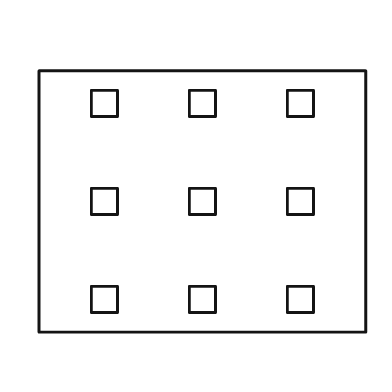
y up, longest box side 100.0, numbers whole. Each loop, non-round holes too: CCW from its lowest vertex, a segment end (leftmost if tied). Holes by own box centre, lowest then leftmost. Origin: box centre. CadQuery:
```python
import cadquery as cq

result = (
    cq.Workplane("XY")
    .moveTo(-50.0, -40.0)
    .lineTo(50.0, -40.0)
    .lineTo(50.0, 40.0)
    .lineTo(-50.0, 40.0)
    .close()
    .moveTo(-34.0, -34.0)
    .lineTo(-26.0, -34.0)
    .lineTo(-26.0, -26.0)
    .lineTo(-34.0, -26.0)
    .close()
    .moveTo(-4.0, -34.0)
    .lineTo(4.0, -34.0)
    .lineTo(4.0, -26.0)
    .lineTo(-4.0, -26.0)
    .close()
    .moveTo(26.0, -34.0)
    .lineTo(34.0, -34.0)
    .lineTo(34.0, -26.0)
    .lineTo(26.0, -26.0)
    .close()
    .moveTo(-34.0, -4.0)
    .lineTo(-26.0, -4.0)
    .lineTo(-26.0, 4.0)
    .lineTo(-34.0, 4.0)
    .close()
    .moveTo(-4.0, -4.0)
    .lineTo(4.0, -4.0)
    .lineTo(4.0, 4.0)
    .lineTo(-4.0, 4.0)
    .close()
    .moveTo(26.0, -4.0)
    .lineTo(34.0, -4.0)
    .lineTo(34.0, 4.0)
    .lineTo(26.0, 4.0)
    .close()
    .moveTo(-34.0, 26.0)
    .lineTo(-26.0, 26.0)
    .lineTo(-26.0, 34.0)
    .lineTo(-34.0, 34.0)
    .close()
    .moveTo(-4.0, 26.0)
    .lineTo(4.0, 26.0)
    .lineTo(4.0, 34.0)
    .lineTo(-4.0, 34.0)
    .close()
    .moveTo(26.0, 26.0)
    .lineTo(34.0, 26.0)
    .lineTo(34.0, 34.0)
    .lineTo(26.0, 34.0)
    .close()
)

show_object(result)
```